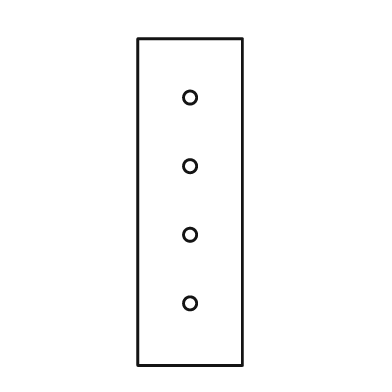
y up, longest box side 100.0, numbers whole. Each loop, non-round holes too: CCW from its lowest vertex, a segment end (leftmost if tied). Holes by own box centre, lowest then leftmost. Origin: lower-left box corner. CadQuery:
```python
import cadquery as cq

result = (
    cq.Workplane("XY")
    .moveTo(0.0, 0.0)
    .lineTo(32.0, 0.0)
    .lineTo(32.0, 100.0)
    .lineTo(0.0, 100.0)
    .close()
    .moveTo(16.0, 19.0)
    .circle(2.0)
    .moveTo(16.0, 40.0)
    .circle(2.0)
    .moveTo(16.0, 61.0)
    .circle(2.0)
    .moveTo(16.0, 82.0)
    .circle(2.0)
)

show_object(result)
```